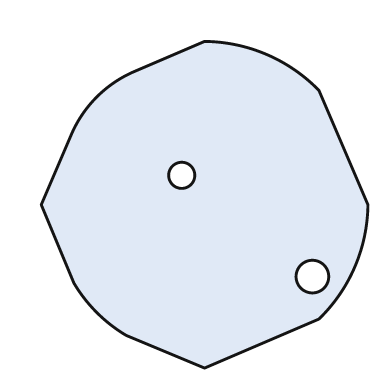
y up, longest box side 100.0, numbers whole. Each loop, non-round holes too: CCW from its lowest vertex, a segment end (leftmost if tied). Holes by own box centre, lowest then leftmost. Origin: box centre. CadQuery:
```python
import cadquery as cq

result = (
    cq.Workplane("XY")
    .moveTo(0.0, -50.0)
    .lineTo(35.0, -35.0)
    .threePointArc((46.0, -19.0), (50.0, 0.0))
    .lineTo(35.0, 35.0)
    .threePointArc((19.0, 46.0), (0.0, 50.0))
    .lineTo(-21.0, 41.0)
    .threePointArc((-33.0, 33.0), (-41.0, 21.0))
    .lineTo(-50.0, 0.0)
    .lineTo(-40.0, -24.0)
    .threePointArc((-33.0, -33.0), (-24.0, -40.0))
    .close()
    .moveTo(33.0, -22.0)
    .circle(5.0)
    .moveTo(-7.0, 9.0)
    .circle(4.0)
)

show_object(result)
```